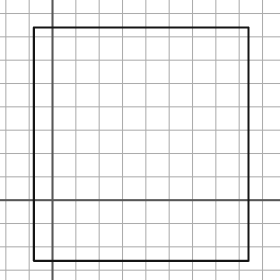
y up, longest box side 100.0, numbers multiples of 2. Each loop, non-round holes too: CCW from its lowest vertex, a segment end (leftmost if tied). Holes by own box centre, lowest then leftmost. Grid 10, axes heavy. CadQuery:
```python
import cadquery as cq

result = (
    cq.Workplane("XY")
    .moveTo(-8.0, -26.0)
    .lineTo(84.0, -26.0)
    .lineTo(84.0, 74.0)
    .lineTo(-8.0, 74.0)
    .close()
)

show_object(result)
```